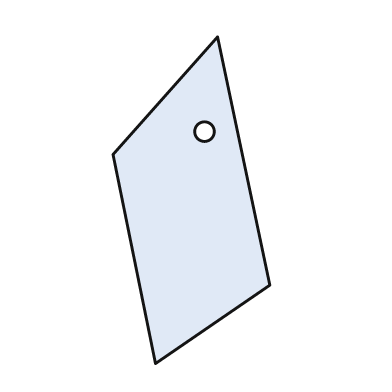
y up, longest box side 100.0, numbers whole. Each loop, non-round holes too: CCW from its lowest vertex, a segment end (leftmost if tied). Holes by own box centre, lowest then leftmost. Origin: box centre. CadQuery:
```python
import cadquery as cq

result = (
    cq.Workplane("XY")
    .moveTo(-11.0, -50.0)
    .lineTo(24.0, -26.0)
    .lineTo(8.0, 50.0)
    .lineTo(-24.0, 14.0)
    .close()
    .moveTo(4.0, 21.0)
    .circle(3.0)
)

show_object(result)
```